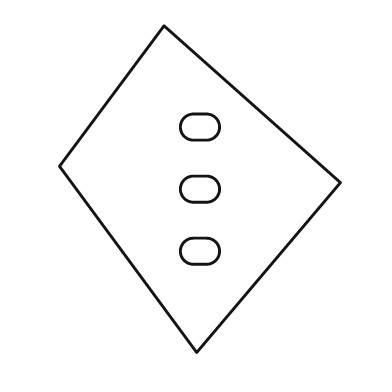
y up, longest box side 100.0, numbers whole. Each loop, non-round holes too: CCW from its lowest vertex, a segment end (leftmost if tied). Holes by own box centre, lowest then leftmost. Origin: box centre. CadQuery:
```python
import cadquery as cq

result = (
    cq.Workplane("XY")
    .moveTo(-1.0, -50.0)
    .lineTo(43.0, 2.0)
    .lineTo(-11.0, 50.0)
    .lineTo(-43.0, 7.0)
    .close()
    .moveTo(-2.0, -23.0)
    .lineTo(2.0, -23.0)
    .threePointArc((6.0, -19.0), (2.0, -15.0))
    .lineTo(-2.0, -15.0)
    .threePointArc((-6.0, -19.0), (-2.0, -23.0))
    .close()
    .moveTo(-2.0, -4.0)
    .lineTo(2.0, -4.0)
    .threePointArc((6.0, 0.0), (2.0, 4.0))
    .lineTo(-2.0, 4.0)
    .threePointArc((-6.0, 0.0), (-2.0, -4.0))
    .close()
    .moveTo(-2.0, 15.0)
    .lineTo(2.0, 15.0)
    .threePointArc((6.0, 19.0), (2.0, 23.0))
    .lineTo(-2.0, 23.0)
    .threePointArc((-6.0, 19.0), (-2.0, 15.0))
    .close()
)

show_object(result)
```